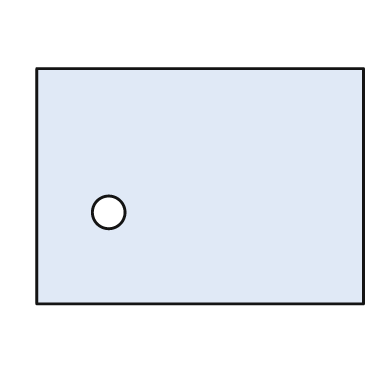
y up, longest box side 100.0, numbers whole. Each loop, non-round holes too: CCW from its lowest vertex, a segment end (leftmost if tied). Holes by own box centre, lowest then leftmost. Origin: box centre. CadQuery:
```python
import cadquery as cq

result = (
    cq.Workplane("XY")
    .moveTo(-50.0, -36.0)
    .lineTo(50.0, -36.0)
    .lineTo(50.0, 36.0)
    .lineTo(-50.0, 36.0)
    .close()
    .moveTo(-28.0, -8.0)
    .circle(5.0)
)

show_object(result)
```